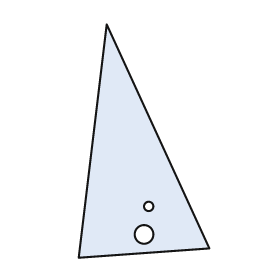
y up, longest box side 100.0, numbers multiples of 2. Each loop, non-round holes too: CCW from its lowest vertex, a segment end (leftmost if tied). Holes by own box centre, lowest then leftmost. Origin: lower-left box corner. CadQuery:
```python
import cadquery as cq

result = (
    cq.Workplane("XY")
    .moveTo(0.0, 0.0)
    .lineTo(56.0, 4.0)
    .lineTo(12.0, 100.0)
    .close()
    .moveTo(28.0, 10.0)
    .circle(4.0)
    .moveTo(30.0, 22.0)
    .circle(2.0)
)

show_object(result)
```